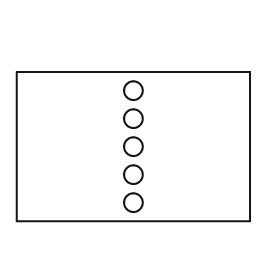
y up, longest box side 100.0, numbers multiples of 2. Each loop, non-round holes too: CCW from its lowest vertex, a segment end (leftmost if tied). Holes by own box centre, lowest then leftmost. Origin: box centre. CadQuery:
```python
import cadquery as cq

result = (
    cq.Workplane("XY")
    .moveTo(-50.0, -32.0)
    .lineTo(50.0, -32.0)
    .lineTo(50.0, 32.0)
    .lineTo(-50.0, 32.0)
    .close()
    .moveTo(0.0, -24.0)
    .circle(4.0)
    .moveTo(0.0, -12.0)
    .circle(4.0)
    .moveTo(0.0, 0.0)
    .circle(4.0)
    .moveTo(0.0, 12.0)
    .circle(4.0)
    .moveTo(0.0, 24.0)
    .circle(4.0)
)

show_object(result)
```